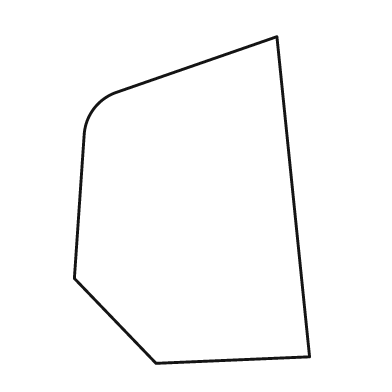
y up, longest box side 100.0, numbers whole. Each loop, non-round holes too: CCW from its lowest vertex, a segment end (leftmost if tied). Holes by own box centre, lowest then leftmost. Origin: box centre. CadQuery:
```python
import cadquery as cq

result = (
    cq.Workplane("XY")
    .moveTo(-11.0, -50.0)
    .lineTo(36.0, -48.0)
    .lineTo(26.0, 50.0)
    .lineTo(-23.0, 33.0)
    .threePointArc((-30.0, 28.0), (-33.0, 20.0))
    .lineTo(-36.0, -24.0)
    .close()
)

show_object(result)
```